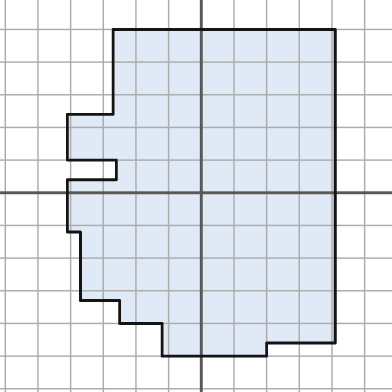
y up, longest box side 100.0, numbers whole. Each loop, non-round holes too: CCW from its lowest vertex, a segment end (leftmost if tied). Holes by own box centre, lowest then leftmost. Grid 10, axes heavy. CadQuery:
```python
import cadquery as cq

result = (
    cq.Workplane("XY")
    .moveTo(-12.0, -50.0)
    .lineTo(20.0, -50.0)
    .lineTo(20.0, -46.0)
    .lineTo(41.0, -46.0)
    .lineTo(41.0, 50.0)
    .lineTo(-27.0, 50.0)
    .lineTo(-27.0, 24.0)
    .lineTo(-41.0, 24.0)
    .lineTo(-41.0, 10.0)
    .lineTo(-26.0, 10.0)
    .lineTo(-26.0, 4.0)
    .lineTo(-41.0, 4.0)
    .lineTo(-41.0, -12.0)
    .lineTo(-37.0, -12.0)
    .lineTo(-37.0, -33.0)
    .lineTo(-25.0, -33.0)
    .lineTo(-25.0, -40.0)
    .lineTo(-12.0, -40.0)
    .close()
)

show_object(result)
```